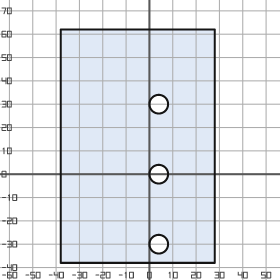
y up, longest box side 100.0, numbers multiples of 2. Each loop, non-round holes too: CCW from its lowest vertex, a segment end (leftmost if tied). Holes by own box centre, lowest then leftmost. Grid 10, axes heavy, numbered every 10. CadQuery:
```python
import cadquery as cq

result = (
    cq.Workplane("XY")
    .moveTo(-38.0, -38.0)
    .lineTo(28.0, -38.0)
    .lineTo(28.0, 62.0)
    .lineTo(-38.0, 62.0)
    .close()
    .moveTo(4.0, -30.0)
    .circle(4.0)
    .moveTo(4.0, 0.0)
    .circle(4.0)
    .moveTo(4.0, 30.0)
    .circle(4.0)
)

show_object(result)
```